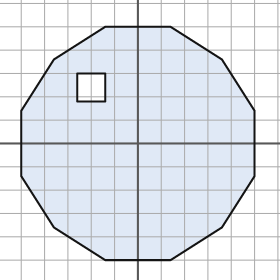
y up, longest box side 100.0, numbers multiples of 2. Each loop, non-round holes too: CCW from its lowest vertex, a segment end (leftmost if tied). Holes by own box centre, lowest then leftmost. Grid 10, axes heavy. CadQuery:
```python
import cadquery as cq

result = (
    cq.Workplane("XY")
    .moveTo(-14.0, -50.0)
    .lineTo(14.0, -50.0)
    .lineTo(36.0, -36.0)
    .lineTo(50.0, -14.0)
    .lineTo(50.0, 14.0)
    .lineTo(36.0, 36.0)
    .lineTo(14.0, 50.0)
    .lineTo(-14.0, 50.0)
    .lineTo(-36.0, 36.0)
    .lineTo(-50.0, 14.0)
    .lineTo(-50.0, -14.0)
    .lineTo(-36.0, -36.0)
    .close()
    .moveTo(-26.0, 18.0)
    .lineTo(-14.0, 18.0)
    .lineTo(-14.0, 30.0)
    .lineTo(-26.0, 30.0)
    .close()
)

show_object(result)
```